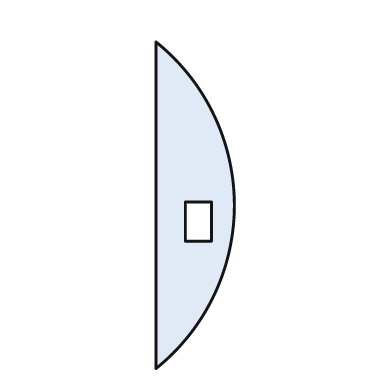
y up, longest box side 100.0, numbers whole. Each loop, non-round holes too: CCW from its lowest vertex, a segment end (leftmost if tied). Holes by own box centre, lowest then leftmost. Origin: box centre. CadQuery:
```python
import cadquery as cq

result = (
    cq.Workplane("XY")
    .moveTo(-12.0, -50.0)
    .threePointArc((12.0, 0.0), (-12.0, 50.0))
    .close()
    .moveTo(-3.0, -11.0)
    .lineTo(5.0, -11.0)
    .lineTo(5.0, 1.0)
    .lineTo(-3.0, 1.0)
    .close()
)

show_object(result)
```